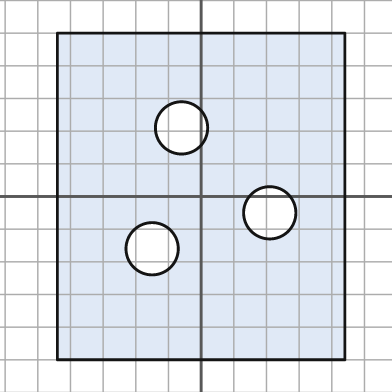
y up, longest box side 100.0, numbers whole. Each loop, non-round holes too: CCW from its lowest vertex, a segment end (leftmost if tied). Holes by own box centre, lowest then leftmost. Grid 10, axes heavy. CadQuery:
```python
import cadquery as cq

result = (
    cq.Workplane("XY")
    .moveTo(-44.0, -50.0)
    .lineTo(44.0, -50.0)
    .lineTo(44.0, 50.0)
    .lineTo(-44.0, 50.0)
    .close()
    .moveTo(-15.0, -16.0)
    .circle(8.0)
    .moveTo(21.0, -5.0)
    .circle(8.0)
    .moveTo(-6.0, 21.0)
    .circle(8.0)
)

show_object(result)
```